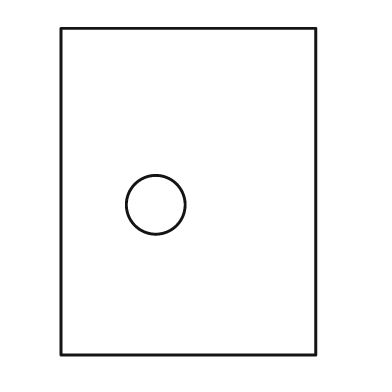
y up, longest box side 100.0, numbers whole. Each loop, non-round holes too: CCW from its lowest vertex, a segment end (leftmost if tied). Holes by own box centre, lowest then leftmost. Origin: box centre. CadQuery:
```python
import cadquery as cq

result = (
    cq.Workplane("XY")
    .moveTo(-39.0, -50.0)
    .lineTo(39.0, -50.0)
    .lineTo(39.0, 50.0)
    .lineTo(-39.0, 50.0)
    .close()
    .moveTo(-10.0, -4.0)
    .circle(9.0)
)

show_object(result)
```